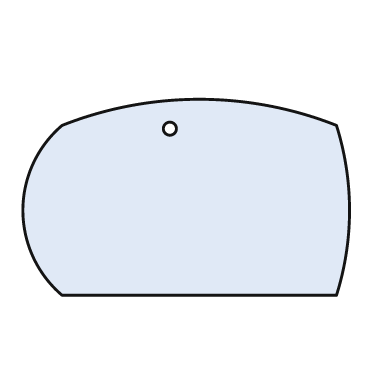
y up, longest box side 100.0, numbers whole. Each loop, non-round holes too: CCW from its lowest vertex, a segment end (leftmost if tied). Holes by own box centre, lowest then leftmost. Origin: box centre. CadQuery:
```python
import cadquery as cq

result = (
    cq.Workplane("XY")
    .moveTo(-38.0, -30.0)
    .lineTo(46.0, -30.0)
    .threePointArc((50.0, -4.0), (46.0, 22.0))
    .threePointArc((4.0, 30.0), (-38.0, 22.0))
    .threePointArc((-50.0, -4.0), (-38.0, -30.0))
    .close()
    .moveTo(-5.0, 21.0)
    .circle(2.0)
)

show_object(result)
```